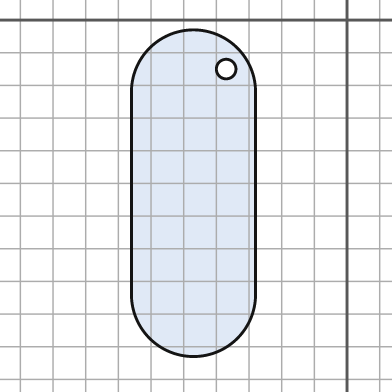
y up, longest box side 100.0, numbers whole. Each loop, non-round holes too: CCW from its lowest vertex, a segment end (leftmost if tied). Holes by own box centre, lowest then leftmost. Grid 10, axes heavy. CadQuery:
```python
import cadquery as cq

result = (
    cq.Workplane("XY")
    .moveTo(-66.0, -84.0)
    .threePointArc((-47.0, -103.0), (-28.0, -84.0))
    .lineTo(-28.0, -22.0)
    .threePointArc((-47.0, -3.0), (-66.0, -22.0))
    .close()
    .moveTo(-37.0, -15.0)
    .circle(3.0)
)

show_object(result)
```